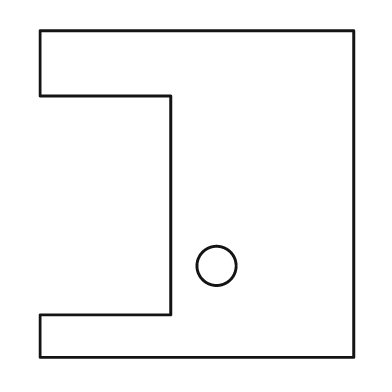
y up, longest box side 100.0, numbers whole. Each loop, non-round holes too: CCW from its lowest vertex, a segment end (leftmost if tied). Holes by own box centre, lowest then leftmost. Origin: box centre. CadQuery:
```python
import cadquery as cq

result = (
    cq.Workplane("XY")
    .moveTo(-48.0, -50.0)
    .lineTo(48.0, -50.0)
    .lineTo(48.0, 50.0)
    .lineTo(-48.0, 50.0)
    .lineTo(-48.0, 30.0)
    .lineTo(-8.0, 30.0)
    .lineTo(-8.0, -37.0)
    .lineTo(-48.0, -37.0)
    .close()
    .moveTo(6.0, -22.0)
    .circle(6.0)
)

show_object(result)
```